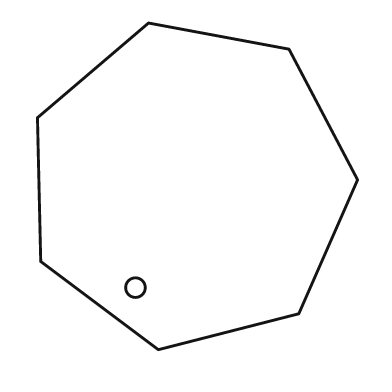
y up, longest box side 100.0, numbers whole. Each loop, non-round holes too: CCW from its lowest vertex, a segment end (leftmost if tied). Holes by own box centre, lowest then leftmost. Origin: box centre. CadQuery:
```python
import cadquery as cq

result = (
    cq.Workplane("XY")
    .moveTo(-12.0, -50.0)
    .lineTo(31.0, -39.0)
    .lineTo(49.0, 2.0)
    .lineTo(28.0, 42.0)
    .lineTo(-15.0, 50.0)
    .lineTo(-49.0, 21.0)
    .lineTo(-48.0, -23.0)
    .close()
    .moveTo(-19.0, -31.0)
    .circle(3.0)
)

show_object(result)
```